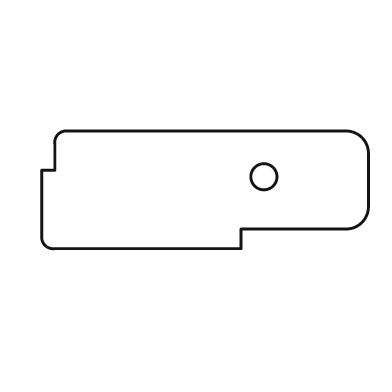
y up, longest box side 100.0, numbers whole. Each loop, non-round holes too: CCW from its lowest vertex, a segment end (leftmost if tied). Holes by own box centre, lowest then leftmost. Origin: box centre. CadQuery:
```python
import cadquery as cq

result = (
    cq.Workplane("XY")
    .moveTo(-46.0, -18.0)
    .lineTo(11.0, -18.0)
    .lineTo(11.0, -12.0)
    .lineTo(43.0, -12.0)
    .threePointArc((48.0, -10.0), (50.0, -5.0))
    .lineTo(50.0, 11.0)
    .threePointArc((48.0, 16.0), (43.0, 18.0))
    .lineTo(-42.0, 18.0)
    .threePointArc((-45.0, 17.0), (-46.0, 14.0))
    .lineTo(-46.0, 6.0)
    .lineTo(-50.0, 6.0)
    .lineTo(-50.0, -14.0)
    .threePointArc((-49.0, -17.0), (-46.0, -18.0))
    .close()
    .moveTo(18.0, 4.0)
    .circle(4.0)
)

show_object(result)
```